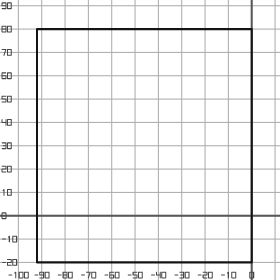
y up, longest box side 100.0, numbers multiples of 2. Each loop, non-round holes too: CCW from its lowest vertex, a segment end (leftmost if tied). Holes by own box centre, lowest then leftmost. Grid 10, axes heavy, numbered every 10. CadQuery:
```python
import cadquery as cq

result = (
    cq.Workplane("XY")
    .moveTo(-92.0, -20.0)
    .lineTo(0.0, -20.0)
    .lineTo(0.0, 80.0)
    .lineTo(-92.0, 80.0)
    .close()
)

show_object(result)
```